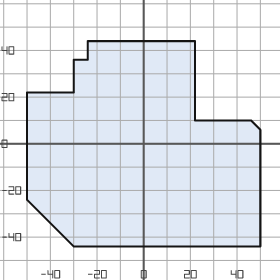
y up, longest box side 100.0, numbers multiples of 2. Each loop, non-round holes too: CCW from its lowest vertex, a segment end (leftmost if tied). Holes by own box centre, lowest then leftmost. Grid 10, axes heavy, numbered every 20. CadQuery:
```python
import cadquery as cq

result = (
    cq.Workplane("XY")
    .moveTo(-30.0, -44.0)
    .lineTo(50.0, -44.0)
    .lineTo(50.0, 6.0)
    .lineTo(46.0, 10.0)
    .lineTo(22.0, 10.0)
    .lineTo(22.0, 44.0)
    .lineTo(-24.0, 44.0)
    .lineTo(-24.0, 36.0)
    .lineTo(-30.0, 36.0)
    .lineTo(-30.0, 22.0)
    .lineTo(-50.0, 22.0)
    .lineTo(-50.0, -24.0)
    .close()
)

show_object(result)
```